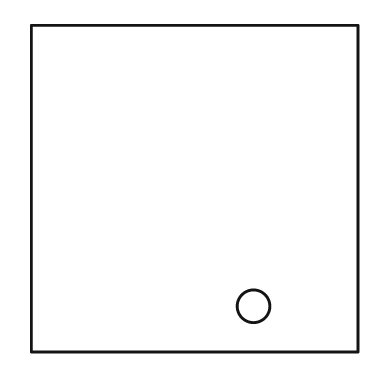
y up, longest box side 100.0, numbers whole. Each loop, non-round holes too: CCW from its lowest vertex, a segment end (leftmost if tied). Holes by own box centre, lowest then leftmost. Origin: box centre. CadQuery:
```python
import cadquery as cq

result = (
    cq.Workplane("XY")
    .moveTo(-50.0, -50.0)
    .lineTo(50.0, -50.0)
    .lineTo(50.0, 50.0)
    .lineTo(-50.0, 50.0)
    .close()
    .moveTo(18.0, -36.0)
    .circle(5.0)
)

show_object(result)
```